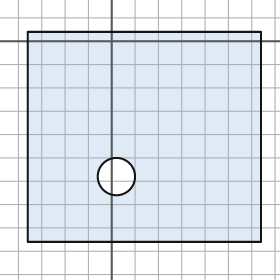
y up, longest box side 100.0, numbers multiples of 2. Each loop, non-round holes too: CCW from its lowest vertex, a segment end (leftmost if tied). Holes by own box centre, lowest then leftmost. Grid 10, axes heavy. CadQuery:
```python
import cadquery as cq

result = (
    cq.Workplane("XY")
    .moveTo(-36.0, -86.0)
    .lineTo(64.0, -86.0)
    .lineTo(64.0, 4.0)
    .lineTo(-36.0, 4.0)
    .close()
    .moveTo(2.0, -58.0)
    .circle(8.0)
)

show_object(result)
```